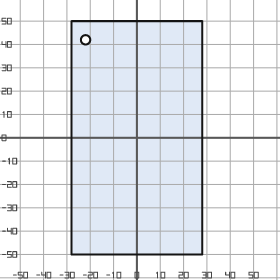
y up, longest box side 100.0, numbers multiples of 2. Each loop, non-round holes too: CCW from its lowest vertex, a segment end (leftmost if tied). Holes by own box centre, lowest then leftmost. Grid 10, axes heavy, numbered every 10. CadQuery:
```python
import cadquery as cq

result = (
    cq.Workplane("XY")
    .moveTo(-28.0, -50.0)
    .lineTo(28.0, -50.0)
    .lineTo(28.0, 50.0)
    .lineTo(-28.0, 50.0)
    .close()
    .moveTo(-22.0, 42.0)
    .circle(2.0)
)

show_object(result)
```